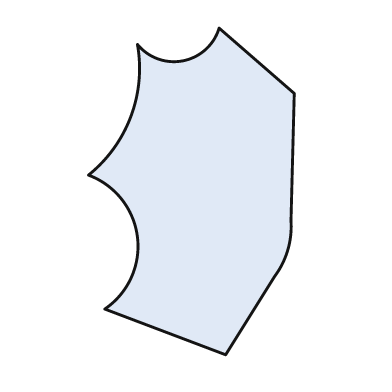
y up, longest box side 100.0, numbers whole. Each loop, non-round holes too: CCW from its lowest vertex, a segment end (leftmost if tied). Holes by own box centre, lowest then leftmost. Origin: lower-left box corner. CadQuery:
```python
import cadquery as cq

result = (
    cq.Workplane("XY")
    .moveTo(42.0, 0.0)
    .lineTo(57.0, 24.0)
    .threePointArc((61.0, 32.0), (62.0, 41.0))
    .lineTo(63.0, 80.0)
    .lineTo(40.0, 100.0)
    .threePointArc((29.0, 90.0), (15.0, 95.0))
    .threePointArc((13.0, 73.0), (0.0, 55.0))
    .threePointArc((15.0, 36.0), (5.0, 14.0))
    .close()
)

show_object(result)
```